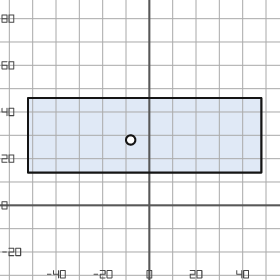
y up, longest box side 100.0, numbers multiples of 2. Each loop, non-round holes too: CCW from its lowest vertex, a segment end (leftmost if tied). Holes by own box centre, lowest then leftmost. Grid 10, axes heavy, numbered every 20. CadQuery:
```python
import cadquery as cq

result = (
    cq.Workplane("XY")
    .moveTo(-52.0, 14.0)
    .lineTo(48.0, 14.0)
    .lineTo(48.0, 46.0)
    .lineTo(-52.0, 46.0)
    .close()
    .moveTo(-8.0, 28.0)
    .circle(2.0)
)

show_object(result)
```